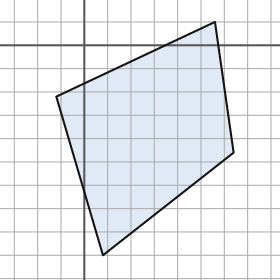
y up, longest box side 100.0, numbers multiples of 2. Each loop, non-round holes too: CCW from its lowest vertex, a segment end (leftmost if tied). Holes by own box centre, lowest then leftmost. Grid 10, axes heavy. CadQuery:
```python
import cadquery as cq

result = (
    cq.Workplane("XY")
    .moveTo(8.0, -90.0)
    .lineTo(64.0, -46.0)
    .lineTo(56.0, 10.0)
    .lineTo(-12.0, -22.0)
    .close()
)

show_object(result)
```